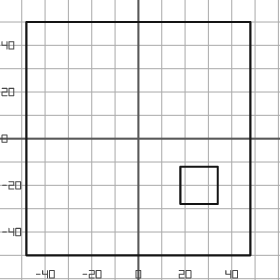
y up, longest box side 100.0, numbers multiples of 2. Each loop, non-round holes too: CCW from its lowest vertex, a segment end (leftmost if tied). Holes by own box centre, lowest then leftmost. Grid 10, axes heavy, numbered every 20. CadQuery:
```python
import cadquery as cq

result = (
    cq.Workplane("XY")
    .moveTo(-48.0, -50.0)
    .lineTo(48.0, -50.0)
    .lineTo(48.0, 50.0)
    .lineTo(-48.0, 50.0)
    .close()
    .moveTo(18.0, -28.0)
    .lineTo(34.0, -28.0)
    .lineTo(34.0, -12.0)
    .lineTo(18.0, -12.0)
    .close()
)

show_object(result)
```